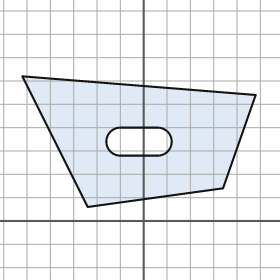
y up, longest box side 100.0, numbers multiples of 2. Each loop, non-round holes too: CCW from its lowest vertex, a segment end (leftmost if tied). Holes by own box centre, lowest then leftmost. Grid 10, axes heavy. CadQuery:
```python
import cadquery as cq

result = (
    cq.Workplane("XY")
    .moveTo(-24.0, 6.0)
    .lineTo(34.0, 14.0)
    .lineTo(48.0, 54.0)
    .lineTo(-52.0, 62.0)
    .close()
    .moveTo(-10.0, 28.0)
    .lineTo(6.0, 28.0)
    .threePointArc((12.0, 34.0), (6.0, 40.0))
    .lineTo(-10.0, 40.0)
    .threePointArc((-16.0, 34.0), (-10.0, 28.0))
    .close()
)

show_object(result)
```